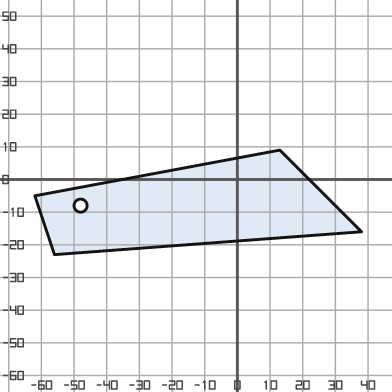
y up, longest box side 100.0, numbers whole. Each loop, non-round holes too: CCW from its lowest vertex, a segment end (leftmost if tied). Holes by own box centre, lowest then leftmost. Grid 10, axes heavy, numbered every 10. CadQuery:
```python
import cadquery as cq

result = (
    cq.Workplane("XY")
    .moveTo(-56.0, -23.0)
    .lineTo(38.0, -16.0)
    .lineTo(13.0, 9.0)
    .lineTo(-62.0, -5.0)
    .close()
    .moveTo(-48.0, -8.0)
    .circle(2.0)
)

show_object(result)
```